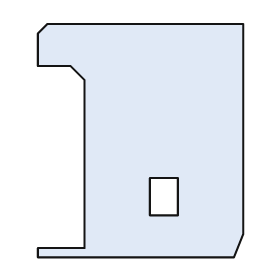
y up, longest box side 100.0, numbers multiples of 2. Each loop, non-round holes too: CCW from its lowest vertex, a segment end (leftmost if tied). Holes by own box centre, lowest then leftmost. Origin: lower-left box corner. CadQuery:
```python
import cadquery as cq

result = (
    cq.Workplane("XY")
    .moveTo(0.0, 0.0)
    .lineTo(84.0, 0.0)
    .lineTo(88.0, 10.0)
    .lineTo(88.0, 100.0)
    .lineTo(4.0, 100.0)
    .lineTo(0.0, 96.0)
    .lineTo(0.0, 82.0)
    .lineTo(14.0, 82.0)
    .lineTo(20.0, 76.0)
    .lineTo(20.0, 4.0)
    .lineTo(0.0, 4.0)
    .close()
    .moveTo(48.0, 18.0)
    .lineTo(60.0, 18.0)
    .lineTo(60.0, 34.0)
    .lineTo(48.0, 34.0)
    .close()
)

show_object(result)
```